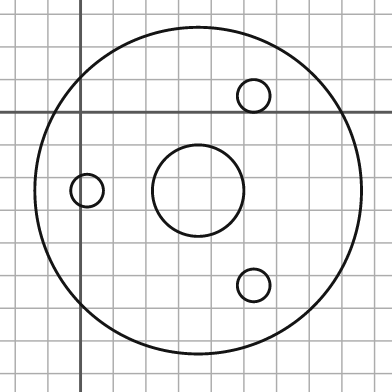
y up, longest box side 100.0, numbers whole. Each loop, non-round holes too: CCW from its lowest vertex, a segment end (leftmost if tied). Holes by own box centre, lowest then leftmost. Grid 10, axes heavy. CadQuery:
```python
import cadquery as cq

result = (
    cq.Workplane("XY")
    .moveTo(36.0, -24.0)
    .circle(50.0)
    .moveTo(53.0, -53.0)
    .circle(5.0)
    .moveTo(2.0, -24.0)
    .circle(5.0)
    .moveTo(36.0, -24.0)
    .circle(14.0)
    .moveTo(53.0, 5.0)
    .circle(5.0)
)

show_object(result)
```